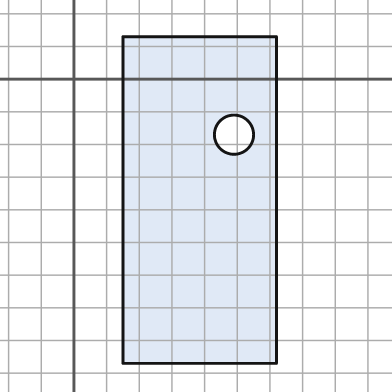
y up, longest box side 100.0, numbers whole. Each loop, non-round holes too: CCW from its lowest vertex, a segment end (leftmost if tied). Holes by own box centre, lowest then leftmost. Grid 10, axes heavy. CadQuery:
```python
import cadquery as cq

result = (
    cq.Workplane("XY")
    .moveTo(15.0, -87.0)
    .lineTo(62.0, -87.0)
    .lineTo(62.0, 13.0)
    .lineTo(15.0, 13.0)
    .close()
    .moveTo(49.0, -17.0)
    .circle(6.0)
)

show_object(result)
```